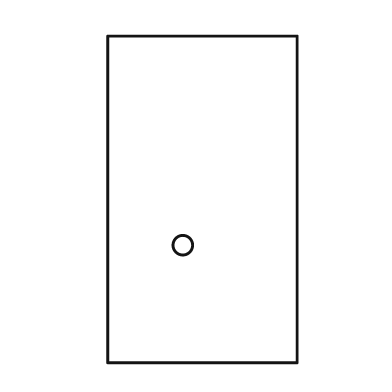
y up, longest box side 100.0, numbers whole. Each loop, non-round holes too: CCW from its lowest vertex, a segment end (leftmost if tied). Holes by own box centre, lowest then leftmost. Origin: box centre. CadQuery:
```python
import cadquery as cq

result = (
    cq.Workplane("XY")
    .moveTo(-29.0, -50.0)
    .lineTo(29.0, -50.0)
    .lineTo(29.0, 50.0)
    .lineTo(-29.0, 50.0)
    .close()
    .moveTo(-6.0, -14.0)
    .circle(3.0)
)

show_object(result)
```